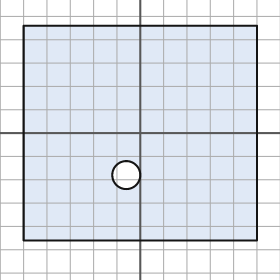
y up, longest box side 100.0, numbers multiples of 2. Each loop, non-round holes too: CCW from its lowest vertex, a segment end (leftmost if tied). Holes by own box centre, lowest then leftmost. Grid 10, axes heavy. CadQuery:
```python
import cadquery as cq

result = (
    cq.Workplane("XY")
    .moveTo(-50.0, -46.0)
    .lineTo(50.0, -46.0)
    .lineTo(50.0, 46.0)
    .lineTo(-50.0, 46.0)
    .close()
    .moveTo(-6.0, -18.0)
    .circle(6.0)
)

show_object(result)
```